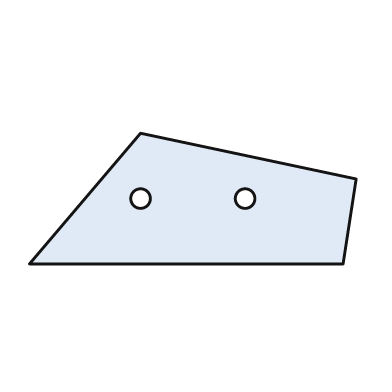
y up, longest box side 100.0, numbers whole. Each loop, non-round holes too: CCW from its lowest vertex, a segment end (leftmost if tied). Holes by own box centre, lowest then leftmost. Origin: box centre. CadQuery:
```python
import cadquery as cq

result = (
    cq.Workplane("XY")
    .moveTo(-50.0, -20.0)
    .lineTo(46.0, -20.0)
    .lineTo(50.0, 6.0)
    .lineTo(-16.0, 20.0)
    .close()
    .moveTo(-16.0, 0.0)
    .circle(3.0)
    .moveTo(16.0, 0.0)
    .circle(3.0)
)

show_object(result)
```